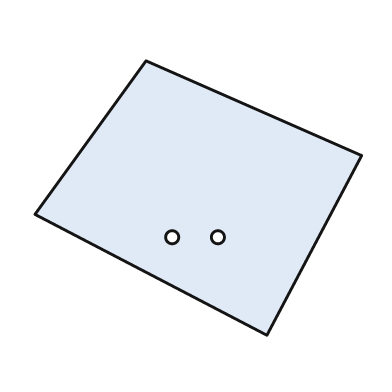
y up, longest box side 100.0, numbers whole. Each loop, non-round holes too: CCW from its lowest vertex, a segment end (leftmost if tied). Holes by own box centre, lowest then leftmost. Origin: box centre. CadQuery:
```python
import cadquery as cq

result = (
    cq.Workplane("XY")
    .moveTo(21.0, -42.0)
    .lineTo(50.0, 13.0)
    .lineTo(-16.0, 42.0)
    .lineTo(-50.0, -5.0)
    .close()
    .moveTo(-8.0, -12.0)
    .circle(2.0)
    .moveTo(6.0, -12.0)
    .circle(2.0)
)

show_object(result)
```